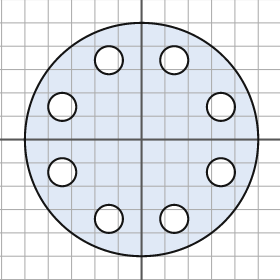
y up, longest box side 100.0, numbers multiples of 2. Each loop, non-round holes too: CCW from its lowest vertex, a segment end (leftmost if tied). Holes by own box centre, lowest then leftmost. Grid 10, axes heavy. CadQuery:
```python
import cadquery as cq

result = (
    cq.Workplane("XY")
    .moveTo(0.0, 0.0)
    .circle(50.0)
    .moveTo(-14.0, -34.0)
    .circle(6.0)
    .moveTo(14.0, -34.0)
    .circle(6.0)
    .moveTo(-34.0, -14.0)
    .circle(6.0)
    .moveTo(34.0, -14.0)
    .circle(6.0)
    .moveTo(-34.0, 14.0)
    .circle(6.0)
    .moveTo(34.0, 14.0)
    .circle(6.0)
    .moveTo(-14.0, 34.0)
    .circle(6.0)
    .moveTo(14.0, 34.0)
    .circle(6.0)
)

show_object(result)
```